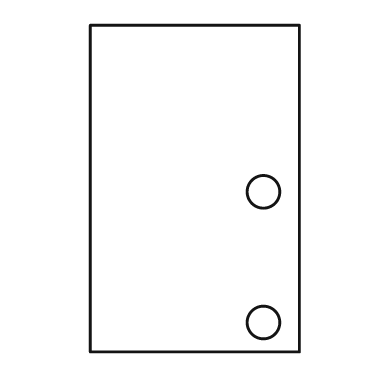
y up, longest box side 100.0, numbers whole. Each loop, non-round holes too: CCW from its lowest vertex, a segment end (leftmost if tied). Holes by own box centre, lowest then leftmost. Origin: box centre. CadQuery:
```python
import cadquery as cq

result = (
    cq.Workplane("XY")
    .moveTo(-32.0, -50.0)
    .lineTo(32.0, -50.0)
    .lineTo(32.0, 50.0)
    .lineTo(-32.0, 50.0)
    .close()
    .moveTo(21.0, -41.0)
    .circle(5.0)
    .moveTo(21.0, -1.0)
    .circle(5.0)
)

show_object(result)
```